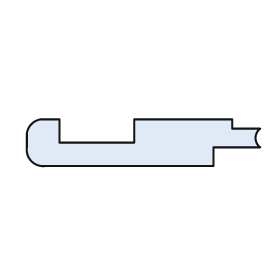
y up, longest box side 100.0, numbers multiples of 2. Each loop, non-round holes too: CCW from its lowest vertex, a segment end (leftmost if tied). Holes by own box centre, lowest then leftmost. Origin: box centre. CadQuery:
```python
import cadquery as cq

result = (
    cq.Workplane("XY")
    .moveTo(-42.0, -10.0)
    .lineTo(30.0, -10.0)
    .lineTo(30.0, -2.0)
    .lineTo(50.0, -2.0)
    .threePointArc((48.0, 2.0), (50.0, 6.0))
    .lineTo(38.0, 6.0)
    .lineTo(38.0, 10.0)
    .lineTo(-4.0, 10.0)
    .lineTo(-4.0, 0.0)
    .lineTo(-36.0, 0.0)
    .lineTo(-36.0, 10.0)
    .lineTo(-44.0, 10.0)
    .threePointArc((-48.0, 8.0), (-50.0, 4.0))
    .lineTo(-50.0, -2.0)
    .threePointArc((-48.0, -8.0), (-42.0, -10.0))
    .close()
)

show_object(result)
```